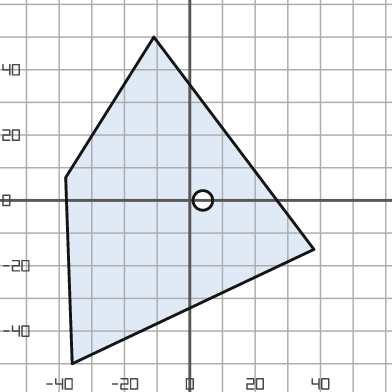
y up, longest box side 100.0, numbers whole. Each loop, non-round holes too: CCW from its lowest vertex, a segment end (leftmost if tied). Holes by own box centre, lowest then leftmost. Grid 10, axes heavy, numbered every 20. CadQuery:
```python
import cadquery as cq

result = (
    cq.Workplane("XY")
    .moveTo(-36.0, -50.0)
    .lineTo(38.0, -15.0)
    .lineTo(-11.0, 50.0)
    .lineTo(-38.0, 7.0)
    .close()
    .moveTo(4.0, 0.0)
    .circle(3.0)
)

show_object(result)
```